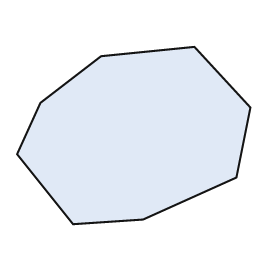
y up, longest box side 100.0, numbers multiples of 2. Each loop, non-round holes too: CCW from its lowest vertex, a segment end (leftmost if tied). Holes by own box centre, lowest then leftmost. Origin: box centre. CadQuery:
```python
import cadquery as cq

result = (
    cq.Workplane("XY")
    .moveTo(-26.0, -38.0)
    .lineTo(4.0, -36.0)
    .lineTo(44.0, -18.0)
    .lineTo(50.0, 12.0)
    .lineTo(26.0, 38.0)
    .lineTo(-14.0, 34.0)
    .lineTo(-40.0, 14.0)
    .lineTo(-50.0, -8.0)
    .close()
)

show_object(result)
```